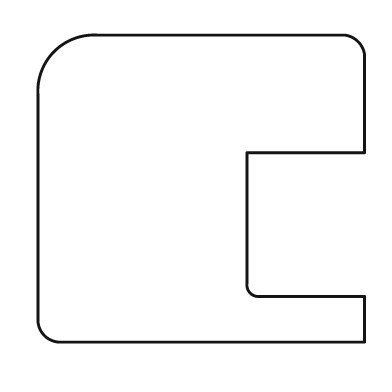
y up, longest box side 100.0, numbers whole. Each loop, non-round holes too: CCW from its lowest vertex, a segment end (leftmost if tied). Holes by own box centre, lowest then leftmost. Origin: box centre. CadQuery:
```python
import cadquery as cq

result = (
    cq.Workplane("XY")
    .moveTo(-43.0, -47.0)
    .lineTo(50.0, -47.0)
    .lineTo(50.0, -33.0)
    .lineTo(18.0, -33.0)
    .threePointArc((15.0, -32.0), (14.0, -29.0))
    .lineTo(14.0, 11.0)
    .lineTo(50.0, 11.0)
    .lineTo(50.0, 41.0)
    .threePointArc((48.0, 45.0), (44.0, 47.0))
    .lineTo(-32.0, 47.0)
    .threePointArc((-45.0, 42.0), (-50.0, 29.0))
    .lineTo(-50.0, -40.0)
    .threePointArc((-48.0, -45.0), (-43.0, -47.0))
    .close()
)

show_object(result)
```